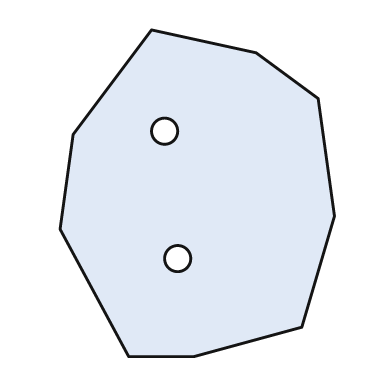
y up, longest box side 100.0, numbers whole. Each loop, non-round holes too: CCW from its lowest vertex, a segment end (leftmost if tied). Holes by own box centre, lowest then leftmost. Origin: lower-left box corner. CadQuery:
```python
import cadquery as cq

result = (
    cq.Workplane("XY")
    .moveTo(21.0, 0.0)
    .lineTo(41.0, 0.0)
    .lineTo(74.0, 9.0)
    .lineTo(84.0, 43.0)
    .lineTo(79.0, 79.0)
    .lineTo(60.0, 93.0)
    .lineTo(28.0, 100.0)
    .lineTo(4.0, 68.0)
    .lineTo(0.0, 39.0)
    .close()
    .moveTo(36.0, 30.0)
    .circle(4.0)
    .moveTo(32.0, 69.0)
    .circle(4.0)
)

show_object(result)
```